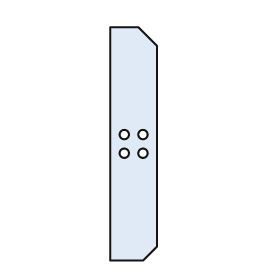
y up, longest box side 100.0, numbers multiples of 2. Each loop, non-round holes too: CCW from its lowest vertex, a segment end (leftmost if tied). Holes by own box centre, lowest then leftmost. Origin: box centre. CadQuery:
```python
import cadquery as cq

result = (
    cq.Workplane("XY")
    .moveTo(-10.0, -50.0)
    .lineTo(4.0, -50.0)
    .lineTo(10.0, -44.0)
    .lineTo(10.0, 42.0)
    .lineTo(2.0, 50.0)
    .lineTo(-10.0, 50.0)
    .close()
    .moveTo(-4.0, -4.0)
    .circle(2.0)
    .moveTo(4.0, -4.0)
    .circle(2.0)
    .moveTo(-4.0, 4.0)
    .circle(2.0)
    .moveTo(4.0, 4.0)
    .circle(2.0)
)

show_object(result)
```